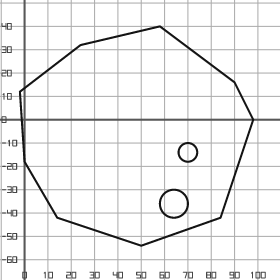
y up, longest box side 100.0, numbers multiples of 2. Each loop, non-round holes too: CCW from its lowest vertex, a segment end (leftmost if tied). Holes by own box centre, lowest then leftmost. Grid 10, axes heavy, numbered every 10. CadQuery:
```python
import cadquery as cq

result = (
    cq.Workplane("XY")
    .moveTo(50.0, -54.0)
    .lineTo(84.0, -42.0)
    .lineTo(98.0, 0.0)
    .lineTo(90.0, 16.0)
    .lineTo(58.0, 40.0)
    .lineTo(24.0, 32.0)
    .lineTo(-2.0, 12.0)
    .lineTo(0.0, -18.0)
    .lineTo(14.0, -42.0)
    .close()
    .moveTo(64.0, -36.0)
    .circle(6.0)
    .moveTo(70.0, -14.0)
    .circle(4.0)
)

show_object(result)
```